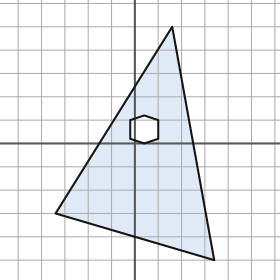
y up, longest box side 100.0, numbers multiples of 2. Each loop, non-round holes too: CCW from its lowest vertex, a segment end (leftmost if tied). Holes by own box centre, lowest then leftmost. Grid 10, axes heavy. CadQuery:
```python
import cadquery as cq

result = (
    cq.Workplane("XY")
    .moveTo(34.0, -50.0)
    .lineTo(16.0, 50.0)
    .lineTo(-34.0, -30.0)
    .close()
    .moveTo(4.0, 0.0)
    .lineTo(10.0, 2.0)
    .lineTo(10.0, 10.0)
    .lineTo(4.0, 12.0)
    .lineTo(-2.0, 10.0)
    .lineTo(-2.0, 2.0)
    .close()
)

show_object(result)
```